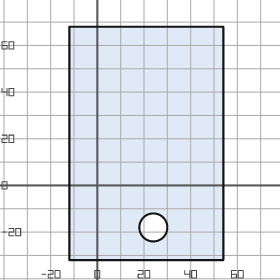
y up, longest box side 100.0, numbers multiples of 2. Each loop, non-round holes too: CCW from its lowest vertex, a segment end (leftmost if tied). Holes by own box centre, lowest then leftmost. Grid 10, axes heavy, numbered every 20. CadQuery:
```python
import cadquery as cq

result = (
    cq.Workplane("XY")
    .moveTo(-12.0, -32.0)
    .lineTo(54.0, -32.0)
    .lineTo(54.0, 68.0)
    .lineTo(-12.0, 68.0)
    .close()
    .moveTo(24.0, -18.0)
    .circle(6.0)
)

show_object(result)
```